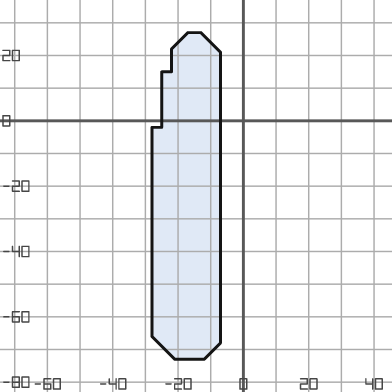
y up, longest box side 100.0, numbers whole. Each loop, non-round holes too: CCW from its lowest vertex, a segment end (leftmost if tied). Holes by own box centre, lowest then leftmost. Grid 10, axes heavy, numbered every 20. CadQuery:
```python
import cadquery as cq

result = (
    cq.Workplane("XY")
    .moveTo(-21.0, -73.0)
    .lineTo(-12.0, -73.0)
    .lineTo(-7.0, -68.0)
    .lineTo(-7.0, 21.0)
    .lineTo(-13.0, 27.0)
    .lineTo(-17.0, 27.0)
    .lineTo(-22.0, 22.0)
    .lineTo(-22.0, 15.0)
    .lineTo(-25.0, 15.0)
    .lineTo(-25.0, -2.0)
    .lineTo(-28.0, -2.0)
    .lineTo(-28.0, -66.0)
    .close()
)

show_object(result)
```